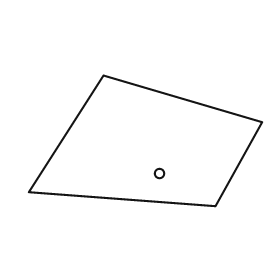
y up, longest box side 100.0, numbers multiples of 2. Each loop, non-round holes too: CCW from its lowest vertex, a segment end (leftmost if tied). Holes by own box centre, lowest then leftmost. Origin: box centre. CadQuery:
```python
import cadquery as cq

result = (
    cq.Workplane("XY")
    .moveTo(30.0, -28.0)
    .lineTo(50.0, 8.0)
    .lineTo(-18.0, 28.0)
    .lineTo(-50.0, -22.0)
    .close()
    .moveTo(6.0, -14.0)
    .circle(2.0)
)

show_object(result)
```